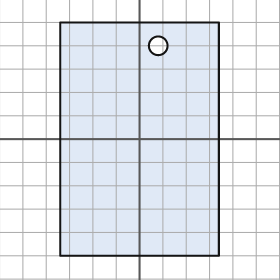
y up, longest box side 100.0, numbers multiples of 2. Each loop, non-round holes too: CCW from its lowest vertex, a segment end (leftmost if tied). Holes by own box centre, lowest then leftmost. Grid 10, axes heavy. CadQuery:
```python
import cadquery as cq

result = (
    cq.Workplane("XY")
    .moveTo(-34.0, -50.0)
    .lineTo(34.0, -50.0)
    .lineTo(34.0, 50.0)
    .lineTo(-34.0, 50.0)
    .close()
    .moveTo(8.0, 40.0)
    .circle(4.0)
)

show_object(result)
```